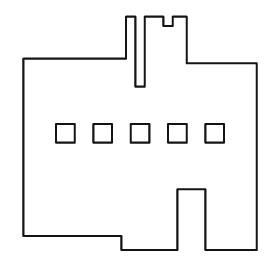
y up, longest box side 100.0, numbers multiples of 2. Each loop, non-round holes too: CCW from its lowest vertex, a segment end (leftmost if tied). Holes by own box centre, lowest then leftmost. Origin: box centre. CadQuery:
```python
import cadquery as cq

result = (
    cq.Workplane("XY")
    .moveTo(-8.0, -50.0)
    .lineTo(16.0, -50.0)
    .lineTo(16.0, -24.0)
    .lineTo(28.0, -24.0)
    .lineTo(28.0, -50.0)
    .lineTo(50.0, -50.0)
    .lineTo(50.0, 30.0)
    .lineTo(20.0, 30.0)
    .lineTo(20.0, 50.0)
    .lineTo(14.0, 50.0)
    .lineTo(14.0, 46.0)
    .lineTo(10.0, 46.0)
    .lineTo(10.0, 50.0)
    .lineTo(2.0, 50.0)
    .lineTo(2.0, 20.0)
    .lineTo(-2.0, 20.0)
    .lineTo(-2.0, 50.0)
    .lineTo(-6.0, 50.0)
    .lineTo(-6.0, 32.0)
    .lineTo(-50.0, 32.0)
    .lineTo(-50.0, -44.0)
    .lineTo(-8.0, -44.0)
    .close()
    .moveTo(-36.0, -4.0)
    .lineTo(-28.0, -4.0)
    .lineTo(-28.0, 4.0)
    .lineTo(-36.0, 4.0)
    .close()
    .moveTo(-20.0, -4.0)
    .lineTo(-12.0, -4.0)
    .lineTo(-12.0, 4.0)
    .lineTo(-20.0, 4.0)
    .close()
    .moveTo(-4.0, -4.0)
    .lineTo(4.0, -4.0)
    .lineTo(4.0, 4.0)
    .lineTo(-4.0, 4.0)
    .close()
    .moveTo(12.0, -4.0)
    .lineTo(20.0, -4.0)
    .lineTo(20.0, 4.0)
    .lineTo(12.0, 4.0)
    .close()
    .moveTo(28.0, -4.0)
    .lineTo(36.0, -4.0)
    .lineTo(36.0, 4.0)
    .lineTo(28.0, 4.0)
    .close()
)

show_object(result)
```